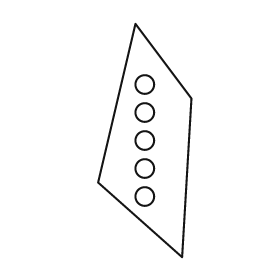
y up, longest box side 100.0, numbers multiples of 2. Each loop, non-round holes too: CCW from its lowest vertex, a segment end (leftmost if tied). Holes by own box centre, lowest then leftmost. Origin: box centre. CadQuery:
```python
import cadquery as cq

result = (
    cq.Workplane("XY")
    .moveTo(16.0, -50.0)
    .lineTo(20.0, 18.0)
    .lineTo(-4.0, 50.0)
    .lineTo(-20.0, -18.0)
    .close()
    .moveTo(0.0, -24.0)
    .circle(4.0)
    .moveTo(0.0, -12.0)
    .circle(4.0)
    .moveTo(0.0, 0.0)
    .circle(4.0)
    .moveTo(0.0, 12.0)
    .circle(4.0)
    .moveTo(0.0, 24.0)
    .circle(4.0)
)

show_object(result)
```